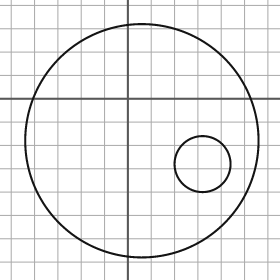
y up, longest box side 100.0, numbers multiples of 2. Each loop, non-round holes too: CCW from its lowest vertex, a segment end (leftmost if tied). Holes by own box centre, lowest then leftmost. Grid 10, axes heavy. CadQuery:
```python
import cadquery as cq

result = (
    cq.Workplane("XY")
    .moveTo(6.0, -18.0)
    .circle(50.0)
    .moveTo(32.0, -28.0)
    .circle(12.0)
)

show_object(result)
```